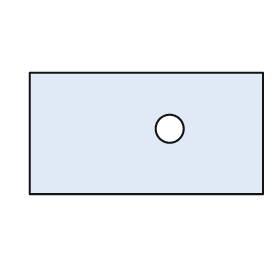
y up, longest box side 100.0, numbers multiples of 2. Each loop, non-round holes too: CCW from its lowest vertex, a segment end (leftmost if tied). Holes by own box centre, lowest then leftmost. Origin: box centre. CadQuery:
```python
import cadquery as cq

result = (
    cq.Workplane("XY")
    .moveTo(-50.0, -26.0)
    .lineTo(50.0, -26.0)
    .lineTo(50.0, 26.0)
    .lineTo(-50.0, 26.0)
    .close()
    .moveTo(10.0, 2.0)
    .circle(6.0)
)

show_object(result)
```